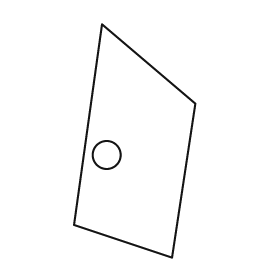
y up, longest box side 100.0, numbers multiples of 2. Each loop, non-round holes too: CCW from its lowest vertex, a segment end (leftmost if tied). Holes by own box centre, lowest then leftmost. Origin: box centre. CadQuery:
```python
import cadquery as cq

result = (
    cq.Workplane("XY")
    .moveTo(16.0, -50.0)
    .lineTo(26.0, 16.0)
    .lineTo(-14.0, 50.0)
    .lineTo(-26.0, -36.0)
    .close()
    .moveTo(-12.0, -6.0)
    .circle(6.0)
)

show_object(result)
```